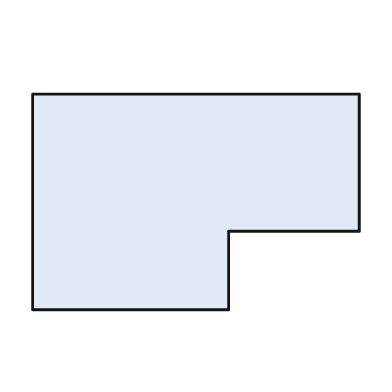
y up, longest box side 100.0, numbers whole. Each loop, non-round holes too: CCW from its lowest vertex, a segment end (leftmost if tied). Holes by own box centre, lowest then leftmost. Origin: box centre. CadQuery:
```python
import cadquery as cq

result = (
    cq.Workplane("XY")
    .moveTo(-50.0, -33.0)
    .lineTo(10.0, -33.0)
    .lineTo(10.0, -9.0)
    .lineTo(50.0, -9.0)
    .lineTo(50.0, 33.0)
    .lineTo(-50.0, 33.0)
    .close()
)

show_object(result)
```